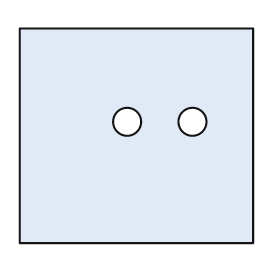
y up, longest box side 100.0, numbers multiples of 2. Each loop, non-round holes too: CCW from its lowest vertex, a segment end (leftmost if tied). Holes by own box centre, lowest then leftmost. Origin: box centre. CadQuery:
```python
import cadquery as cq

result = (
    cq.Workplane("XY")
    .moveTo(-50.0, -46.0)
    .lineTo(50.0, -46.0)
    .lineTo(50.0, 46.0)
    .lineTo(-50.0, 46.0)
    .close()
    .moveTo(-4.0, 6.0)
    .circle(6.0)
    .moveTo(24.0, 6.0)
    .circle(6.0)
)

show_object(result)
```